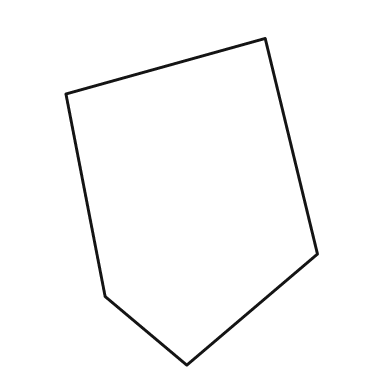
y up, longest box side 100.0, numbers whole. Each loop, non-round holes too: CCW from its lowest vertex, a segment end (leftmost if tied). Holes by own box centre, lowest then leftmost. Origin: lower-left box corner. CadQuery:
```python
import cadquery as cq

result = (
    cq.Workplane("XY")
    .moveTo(37.0, 0.0)
    .lineTo(77.0, 34.0)
    .lineTo(61.0, 100.0)
    .lineTo(0.0, 83.0)
    .lineTo(12.0, 21.0)
    .close()
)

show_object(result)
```